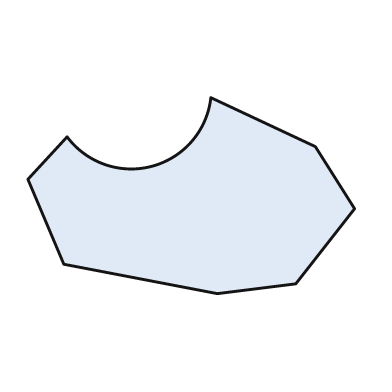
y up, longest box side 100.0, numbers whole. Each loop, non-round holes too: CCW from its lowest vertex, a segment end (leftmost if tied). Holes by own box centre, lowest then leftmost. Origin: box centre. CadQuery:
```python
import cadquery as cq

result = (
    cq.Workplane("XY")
    .moveTo(8.0, -30.0)
    .lineTo(32.0, -27.0)
    .lineTo(50.0, -4.0)
    .lineTo(38.0, 15.0)
    .lineTo(6.0, 30.0)
    .threePointArc((-12.0, 9.0), (-38.0, 18.0))
    .lineTo(-50.0, 5.0)
    .lineTo(-39.0, -21.0)
    .close()
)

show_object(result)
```